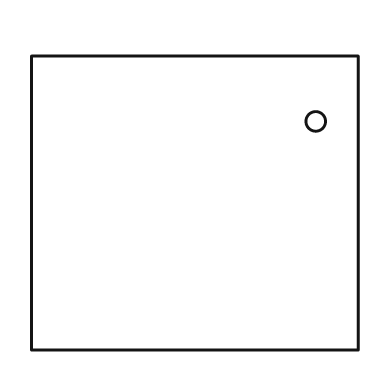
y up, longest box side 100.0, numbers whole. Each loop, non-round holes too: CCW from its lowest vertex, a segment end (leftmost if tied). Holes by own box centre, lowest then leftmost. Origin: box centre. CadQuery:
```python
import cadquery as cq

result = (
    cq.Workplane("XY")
    .moveTo(-50.0, -45.0)
    .lineTo(50.0, -45.0)
    .lineTo(50.0, 45.0)
    .lineTo(-50.0, 45.0)
    .close()
    .moveTo(37.0, 25.0)
    .circle(3.0)
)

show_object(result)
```